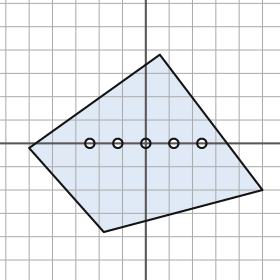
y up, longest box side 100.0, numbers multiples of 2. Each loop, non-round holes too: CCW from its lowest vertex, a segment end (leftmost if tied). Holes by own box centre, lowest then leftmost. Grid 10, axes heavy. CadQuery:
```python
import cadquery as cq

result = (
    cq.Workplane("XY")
    .moveTo(-18.0, -38.0)
    .lineTo(50.0, -20.0)
    .lineTo(6.0, 38.0)
    .lineTo(-50.0, -2.0)
    .close()
    .moveTo(-24.0, 0.0)
    .circle(2.0)
    .moveTo(-12.0, 0.0)
    .circle(2.0)
    .moveTo(0.0, 0.0)
    .circle(2.0)
    .moveTo(12.0, 0.0)
    .circle(2.0)
    .moveTo(24.0, 0.0)
    .circle(2.0)
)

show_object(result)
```